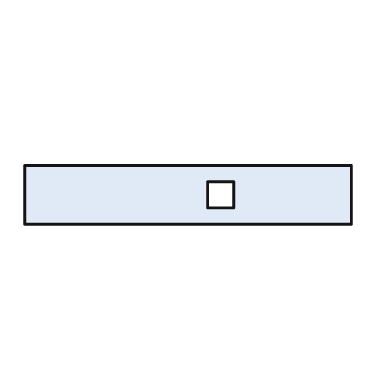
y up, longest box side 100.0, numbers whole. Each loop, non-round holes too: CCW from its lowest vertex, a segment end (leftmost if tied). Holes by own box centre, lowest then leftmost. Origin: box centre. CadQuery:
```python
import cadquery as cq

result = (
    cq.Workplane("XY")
    .moveTo(-50.0, -9.0)
    .lineTo(50.0, -9.0)
    .lineTo(50.0, 9.0)
    .lineTo(-50.0, 9.0)
    .close()
    .moveTo(6.0, -4.0)
    .lineTo(14.0, -4.0)
    .lineTo(14.0, 4.0)
    .lineTo(6.0, 4.0)
    .close()
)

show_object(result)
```